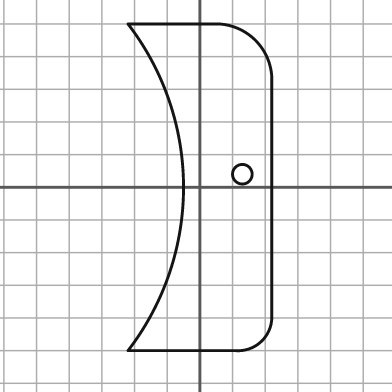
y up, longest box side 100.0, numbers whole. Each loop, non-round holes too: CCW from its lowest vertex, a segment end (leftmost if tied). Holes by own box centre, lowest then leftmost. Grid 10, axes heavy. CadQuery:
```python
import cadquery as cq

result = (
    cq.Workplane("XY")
    .moveTo(-22.0, -50.0)
    .lineTo(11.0, -50.0)
    .threePointArc((19.0, -47.0), (22.0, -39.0))
    .lineTo(22.0, 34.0)
    .threePointArc((17.0, 45.0), (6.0, 50.0))
    .lineTo(-22.0, 50.0)
    .threePointArc((-5.0, 0.0), (-22.0, -50.0))
    .close()
    .moveTo(13.0, 4.0)
    .circle(3.0)
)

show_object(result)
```